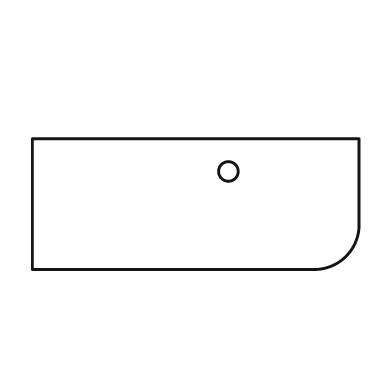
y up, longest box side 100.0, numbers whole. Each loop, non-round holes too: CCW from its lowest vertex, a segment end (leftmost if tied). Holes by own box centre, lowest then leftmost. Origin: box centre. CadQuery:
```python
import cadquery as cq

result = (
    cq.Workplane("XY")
    .moveTo(-50.0, -20.0)
    .lineTo(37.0, -20.0)
    .threePointArc((46.0, -16.0), (50.0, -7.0))
    .lineTo(50.0, 20.0)
    .lineTo(-50.0, 20.0)
    .close()
    .moveTo(10.0, 10.0)
    .circle(3.0)
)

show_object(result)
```